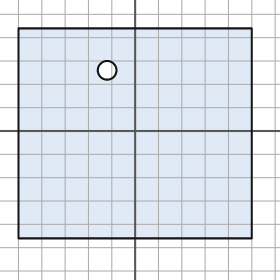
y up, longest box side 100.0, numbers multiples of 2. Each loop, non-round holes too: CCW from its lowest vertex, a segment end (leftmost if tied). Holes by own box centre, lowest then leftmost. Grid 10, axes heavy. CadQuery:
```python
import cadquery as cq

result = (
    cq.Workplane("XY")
    .moveTo(-50.0, -46.0)
    .lineTo(50.0, -46.0)
    .lineTo(50.0, 44.0)
    .lineTo(-50.0, 44.0)
    .close()
    .moveTo(-12.0, 26.0)
    .circle(4.0)
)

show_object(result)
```